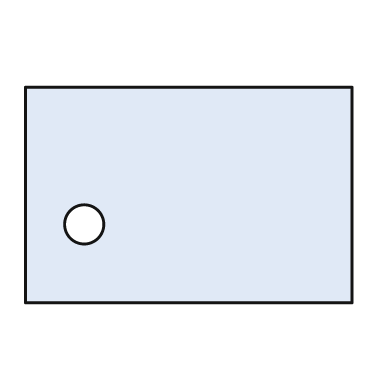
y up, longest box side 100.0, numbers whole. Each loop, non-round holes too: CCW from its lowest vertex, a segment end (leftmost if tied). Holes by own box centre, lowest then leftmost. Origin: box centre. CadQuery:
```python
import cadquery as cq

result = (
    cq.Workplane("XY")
    .moveTo(-50.0, -33.0)
    .lineTo(50.0, -33.0)
    .lineTo(50.0, 33.0)
    .lineTo(-50.0, 33.0)
    .close()
    .moveTo(-32.0, -9.0)
    .circle(6.0)
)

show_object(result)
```